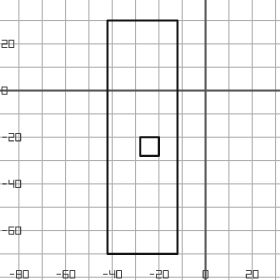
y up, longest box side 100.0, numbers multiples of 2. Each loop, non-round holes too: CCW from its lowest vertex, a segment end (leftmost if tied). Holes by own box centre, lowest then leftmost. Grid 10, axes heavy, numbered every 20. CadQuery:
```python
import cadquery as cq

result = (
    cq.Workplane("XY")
    .moveTo(-42.0, -70.0)
    .lineTo(-12.0, -70.0)
    .lineTo(-12.0, 30.0)
    .lineTo(-42.0, 30.0)
    .close()
    .moveTo(-28.0, -28.0)
    .lineTo(-20.0, -28.0)
    .lineTo(-20.0, -20.0)
    .lineTo(-28.0, -20.0)
    .close()
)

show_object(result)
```